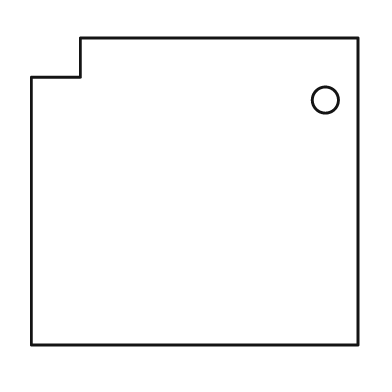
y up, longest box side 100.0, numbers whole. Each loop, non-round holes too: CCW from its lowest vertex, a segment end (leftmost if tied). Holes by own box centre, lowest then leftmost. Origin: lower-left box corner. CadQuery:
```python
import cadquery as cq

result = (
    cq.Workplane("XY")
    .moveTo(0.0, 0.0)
    .lineTo(100.0, 0.0)
    .lineTo(100.0, 94.0)
    .lineTo(15.0, 94.0)
    .lineTo(15.0, 82.0)
    .lineTo(0.0, 82.0)
    .close()
    .moveTo(90.0, 75.0)
    .circle(4.0)
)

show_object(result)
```